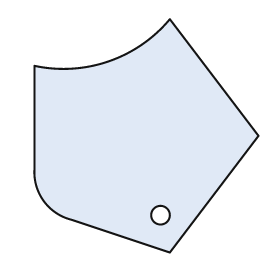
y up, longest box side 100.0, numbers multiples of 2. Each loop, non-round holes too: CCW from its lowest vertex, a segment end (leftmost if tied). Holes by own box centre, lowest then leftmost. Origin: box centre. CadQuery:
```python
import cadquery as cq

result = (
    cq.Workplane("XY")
    .moveTo(10.0, -50.0)
    .lineTo(48.0, 0.0)
    .lineTo(10.0, 50.0)
    .threePointArc((-16.0, 32.0), (-48.0, 30.0))
    .lineTo(-48.0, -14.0)
    .threePointArc((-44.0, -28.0), (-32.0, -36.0))
    .close()
    .moveTo(6.0, -34.0)
    .circle(4.0)
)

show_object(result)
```